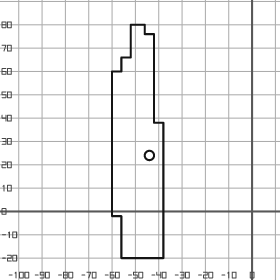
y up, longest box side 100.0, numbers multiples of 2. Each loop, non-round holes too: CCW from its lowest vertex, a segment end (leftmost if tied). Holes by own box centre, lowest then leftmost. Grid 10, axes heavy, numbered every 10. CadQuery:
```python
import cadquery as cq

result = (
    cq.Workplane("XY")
    .moveTo(-56.0, -20.0)
    .lineTo(-38.0, -20.0)
    .lineTo(-38.0, 38.0)
    .lineTo(-42.0, 38.0)
    .lineTo(-42.0, 76.0)
    .lineTo(-46.0, 76.0)
    .lineTo(-46.0, 80.0)
    .lineTo(-52.0, 80.0)
    .lineTo(-52.0, 66.0)
    .lineTo(-56.0, 66.0)
    .lineTo(-56.0, 60.0)
    .lineTo(-60.0, 60.0)
    .lineTo(-60.0, -2.0)
    .lineTo(-56.0, -2.0)
    .close()
    .moveTo(-44.0, 24.0)
    .circle(2.0)
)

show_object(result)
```